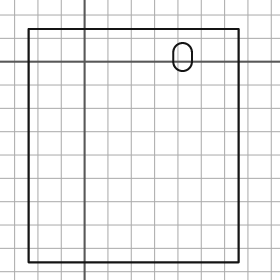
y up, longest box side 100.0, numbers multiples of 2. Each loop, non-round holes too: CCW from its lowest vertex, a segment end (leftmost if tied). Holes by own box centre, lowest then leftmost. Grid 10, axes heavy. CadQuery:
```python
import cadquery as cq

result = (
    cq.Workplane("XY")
    .moveTo(-24.0, -86.0)
    .lineTo(66.0, -86.0)
    .lineTo(66.0, 14.0)
    .lineTo(-24.0, 14.0)
    .close()
    .moveTo(38.0, 0.0)
    .threePointArc((42.0, -4.0), (46.0, 0.0))
    .lineTo(46.0, 4.0)
    .threePointArc((42.0, 8.0), (38.0, 4.0))
    .close()
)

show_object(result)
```